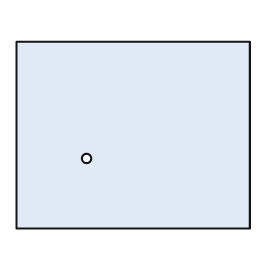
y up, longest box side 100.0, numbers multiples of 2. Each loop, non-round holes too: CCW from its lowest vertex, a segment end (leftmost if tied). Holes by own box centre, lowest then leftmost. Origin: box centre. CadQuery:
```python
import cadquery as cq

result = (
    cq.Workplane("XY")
    .moveTo(-50.0, -40.0)
    .lineTo(50.0, -40.0)
    .lineTo(50.0, 40.0)
    .lineTo(-50.0, 40.0)
    .close()
    .moveTo(-20.0, -10.0)
    .circle(2.0)
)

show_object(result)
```